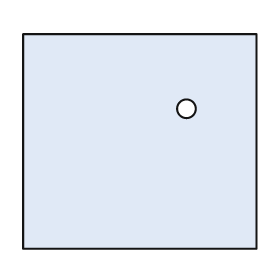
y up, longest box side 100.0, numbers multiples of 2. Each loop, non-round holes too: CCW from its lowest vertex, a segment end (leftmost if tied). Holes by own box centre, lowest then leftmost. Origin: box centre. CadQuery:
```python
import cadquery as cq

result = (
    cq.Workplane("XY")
    .moveTo(-50.0, -46.0)
    .lineTo(50.0, -46.0)
    .lineTo(50.0, 46.0)
    .lineTo(-50.0, 46.0)
    .close()
    .moveTo(20.0, 14.0)
    .circle(4.0)
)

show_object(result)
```